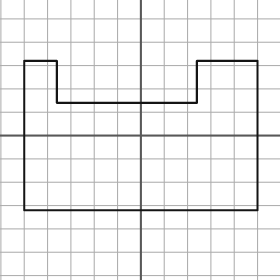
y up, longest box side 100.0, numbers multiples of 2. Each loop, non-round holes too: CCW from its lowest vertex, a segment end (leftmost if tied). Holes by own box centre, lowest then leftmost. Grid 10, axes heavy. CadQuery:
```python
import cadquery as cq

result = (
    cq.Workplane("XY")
    .moveTo(-50.0, -32.0)
    .lineTo(50.0, -32.0)
    .lineTo(50.0, 32.0)
    .lineTo(24.0, 32.0)
    .lineTo(24.0, 14.0)
    .lineTo(-36.0, 14.0)
    .lineTo(-36.0, 32.0)
    .lineTo(-50.0, 32.0)
    .close()
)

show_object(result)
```